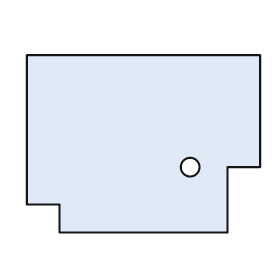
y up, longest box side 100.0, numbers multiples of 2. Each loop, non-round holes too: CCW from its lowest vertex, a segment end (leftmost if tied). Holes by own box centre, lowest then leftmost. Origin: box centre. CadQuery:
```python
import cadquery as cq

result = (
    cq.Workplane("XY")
    .moveTo(-36.0, -38.0)
    .lineTo(36.0, -38.0)
    .lineTo(36.0, -10.0)
    .lineTo(50.0, -10.0)
    .lineTo(50.0, 38.0)
    .lineTo(-50.0, 38.0)
    .lineTo(-50.0, -26.0)
    .lineTo(-36.0, -26.0)
    .close()
    .moveTo(20.0, -10.0)
    .circle(4.0)
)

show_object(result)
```